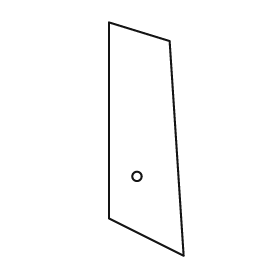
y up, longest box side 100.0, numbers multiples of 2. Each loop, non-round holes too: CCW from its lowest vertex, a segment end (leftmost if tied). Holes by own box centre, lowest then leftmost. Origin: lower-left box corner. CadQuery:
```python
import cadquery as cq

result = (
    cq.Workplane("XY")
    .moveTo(32.0, 0.0)
    .lineTo(26.0, 92.0)
    .lineTo(0.0, 100.0)
    .lineTo(0.0, 16.0)
    .close()
    .moveTo(12.0, 34.0)
    .circle(2.0)
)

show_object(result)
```